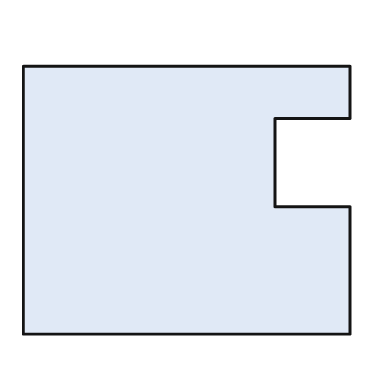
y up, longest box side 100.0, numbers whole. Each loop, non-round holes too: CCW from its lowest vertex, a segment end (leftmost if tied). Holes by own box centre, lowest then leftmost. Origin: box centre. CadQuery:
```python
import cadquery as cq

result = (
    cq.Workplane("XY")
    .moveTo(-50.0, -41.0)
    .lineTo(50.0, -41.0)
    .lineTo(50.0, -2.0)
    .lineTo(27.0, -2.0)
    .lineTo(27.0, 25.0)
    .lineTo(50.0, 25.0)
    .lineTo(50.0, 41.0)
    .lineTo(-50.0, 41.0)
    .close()
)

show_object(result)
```